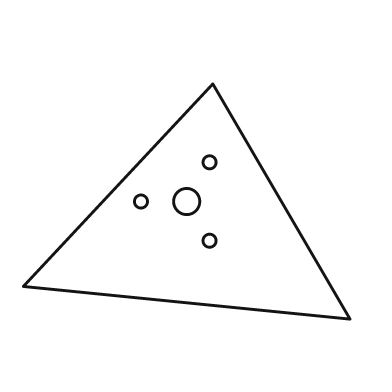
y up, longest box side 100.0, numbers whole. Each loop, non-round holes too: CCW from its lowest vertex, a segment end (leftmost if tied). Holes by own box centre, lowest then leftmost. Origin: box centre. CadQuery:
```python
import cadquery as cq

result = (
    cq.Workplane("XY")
    .moveTo(50.0, -36.0)
    .lineTo(8.0, 36.0)
    .lineTo(-50.0, -26.0)
    .close()
    .moveTo(7.0, -12.0)
    .circle(2.0)
    .moveTo(-14.0, 0.0)
    .circle(2.0)
    .moveTo(0.0, 0.0)
    .circle(4.0)
    .moveTo(7.0, 12.0)
    .circle(2.0)
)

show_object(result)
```